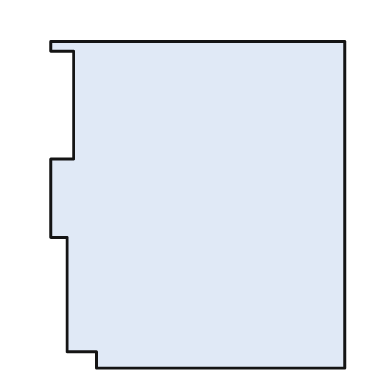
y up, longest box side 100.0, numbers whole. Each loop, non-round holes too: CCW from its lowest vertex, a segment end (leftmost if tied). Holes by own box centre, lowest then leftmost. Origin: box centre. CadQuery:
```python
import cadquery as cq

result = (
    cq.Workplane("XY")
    .moveTo(-31.0, -50.0)
    .lineTo(45.0, -50.0)
    .lineTo(45.0, 50.0)
    .lineTo(-45.0, 50.0)
    .lineTo(-45.0, 47.0)
    .lineTo(-38.0, 47.0)
    .lineTo(-38.0, 14.0)
    .lineTo(-45.0, 14.0)
    .lineTo(-45.0, -10.0)
    .lineTo(-40.0, -10.0)
    .lineTo(-40.0, -45.0)
    .lineTo(-31.0, -45.0)
    .close()
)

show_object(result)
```